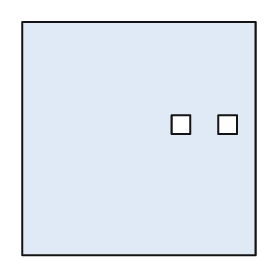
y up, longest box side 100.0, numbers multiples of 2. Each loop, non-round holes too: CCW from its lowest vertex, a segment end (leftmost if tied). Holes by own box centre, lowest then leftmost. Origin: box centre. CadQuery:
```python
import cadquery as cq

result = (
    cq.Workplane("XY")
    .moveTo(-50.0, -50.0)
    .lineTo(50.0, -50.0)
    .lineTo(50.0, 50.0)
    .lineTo(-50.0, 50.0)
    .close()
    .moveTo(14.0, 2.0)
    .lineTo(22.0, 2.0)
    .lineTo(22.0, 10.0)
    .lineTo(14.0, 10.0)
    .close()
    .moveTo(34.0, 2.0)
    .lineTo(42.0, 2.0)
    .lineTo(42.0, 10.0)
    .lineTo(34.0, 10.0)
    .close()
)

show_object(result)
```